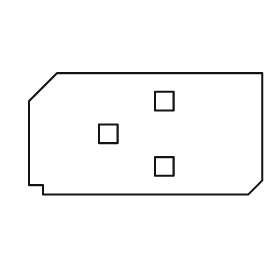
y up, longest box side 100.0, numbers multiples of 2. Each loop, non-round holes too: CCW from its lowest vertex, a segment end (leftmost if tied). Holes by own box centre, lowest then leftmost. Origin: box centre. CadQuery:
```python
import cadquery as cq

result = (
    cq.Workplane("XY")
    .moveTo(-44.0, -26.0)
    .lineTo(44.0, -26.0)
    .lineTo(50.0, -20.0)
    .lineTo(50.0, 26.0)
    .lineTo(-38.0, 26.0)
    .lineTo(-50.0, 14.0)
    .lineTo(-50.0, -22.0)
    .lineTo(-44.0, -22.0)
    .close()
    .moveTo(4.0, -18.0)
    .lineTo(12.0, -18.0)
    .lineTo(12.0, -10.0)
    .lineTo(4.0, -10.0)
    .close()
    .moveTo(-20.0, -4.0)
    .lineTo(-12.0, -4.0)
    .lineTo(-12.0, 4.0)
    .lineTo(-20.0, 4.0)
    .close()
    .moveTo(4.0, 10.0)
    .lineTo(12.0, 10.0)
    .lineTo(12.0, 18.0)
    .lineTo(4.0, 18.0)
    .close()
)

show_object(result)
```